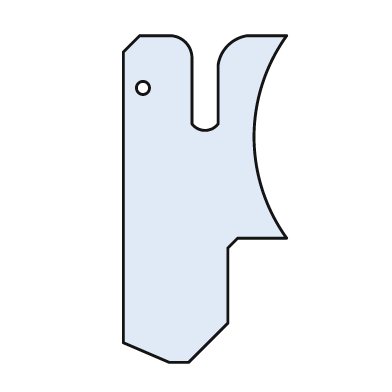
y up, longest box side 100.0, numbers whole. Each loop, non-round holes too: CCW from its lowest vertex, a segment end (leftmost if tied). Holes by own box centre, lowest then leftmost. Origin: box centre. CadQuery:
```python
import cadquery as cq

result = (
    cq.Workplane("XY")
    .moveTo(-11.0, -50.0)
    .lineTo(-5.0, -50.0)
    .lineTo(7.0, -38.0)
    .lineTo(7.0, -15.0)
    .lineTo(10.0, -12.0)
    .lineTo(25.0, -12.0)
    .threePointArc((15.0, 19.0), (25.0, 50.0))
    .lineTo(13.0, 50.0)
    .threePointArc((7.0, 47.0), (4.0, 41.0))
    .lineTo(4.0, 23.0)
    .threePointArc((0.0, 21.0), (-4.0, 23.0))
    .lineTo(-4.0, 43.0)
    .threePointArc((-6.0, 48.0), (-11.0, 50.0))
    .lineTo(-20.0, 50.0)
    .lineTo(-25.0, 45.0)
    .lineTo(-25.0, -44.0)
    .close()
    .moveTo(-19.0, 34.0)
    .circle(2.0)
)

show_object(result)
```